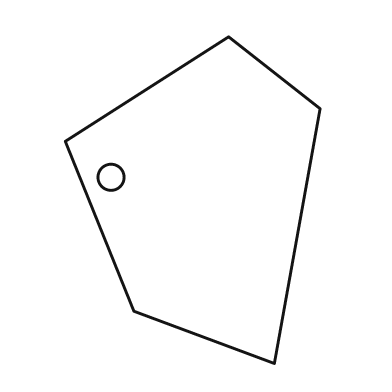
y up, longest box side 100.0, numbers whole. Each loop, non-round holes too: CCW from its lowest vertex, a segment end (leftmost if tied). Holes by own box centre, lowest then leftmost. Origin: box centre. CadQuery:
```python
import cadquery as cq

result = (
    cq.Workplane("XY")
    .moveTo(25.0, -50.0)
    .lineTo(39.0, 28.0)
    .lineTo(11.0, 50.0)
    .lineTo(-39.0, 18.0)
    .lineTo(-18.0, -34.0)
    .close()
    .moveTo(-25.0, 7.0)
    .circle(4.0)
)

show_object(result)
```